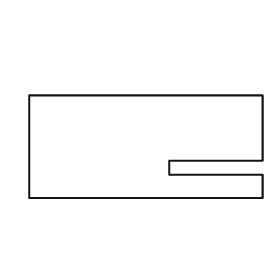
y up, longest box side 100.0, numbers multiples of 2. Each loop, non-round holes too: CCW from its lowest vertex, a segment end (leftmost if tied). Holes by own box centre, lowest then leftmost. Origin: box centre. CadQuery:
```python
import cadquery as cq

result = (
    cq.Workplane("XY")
    .moveTo(-50.0, -22.0)
    .lineTo(50.0, -22.0)
    .lineTo(50.0, -12.0)
    .lineTo(10.0, -12.0)
    .lineTo(10.0, -6.0)
    .lineTo(50.0, -6.0)
    .lineTo(50.0, 22.0)
    .lineTo(-50.0, 22.0)
    .close()
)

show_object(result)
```